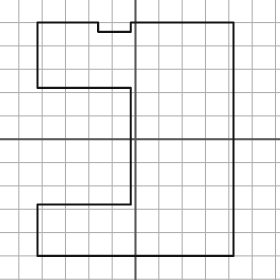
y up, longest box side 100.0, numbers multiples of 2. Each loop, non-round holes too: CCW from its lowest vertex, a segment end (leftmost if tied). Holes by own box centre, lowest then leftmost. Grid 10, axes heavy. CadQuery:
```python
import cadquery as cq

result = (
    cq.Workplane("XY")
    .moveTo(-42.0, -50.0)
    .lineTo(42.0, -50.0)
    .lineTo(42.0, 50.0)
    .lineTo(-2.0, 50.0)
    .lineTo(-2.0, 46.0)
    .lineTo(-16.0, 46.0)
    .lineTo(-16.0, 50.0)
    .lineTo(-42.0, 50.0)
    .lineTo(-42.0, 22.0)
    .lineTo(-2.0, 22.0)
    .lineTo(-2.0, -28.0)
    .lineTo(-42.0, -28.0)
    .close()
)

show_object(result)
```